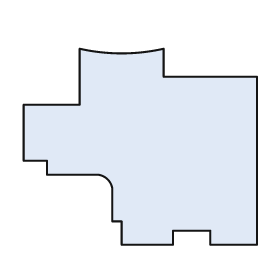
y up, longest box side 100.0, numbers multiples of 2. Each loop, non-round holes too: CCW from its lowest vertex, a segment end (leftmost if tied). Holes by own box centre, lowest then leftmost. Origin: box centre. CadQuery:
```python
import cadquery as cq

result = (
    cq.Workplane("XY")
    .moveTo(-8.0, -42.0)
    .lineTo(14.0, -42.0)
    .lineTo(14.0, -36.0)
    .lineTo(30.0, -36.0)
    .lineTo(30.0, -42.0)
    .lineTo(50.0, -42.0)
    .lineTo(50.0, 30.0)
    .lineTo(10.0, 30.0)
    .lineTo(10.0, 42.0)
    .threePointArc((-8.0, 40.0), (-26.0, 42.0))
    .lineTo(-26.0, 18.0)
    .lineTo(-50.0, 18.0)
    .lineTo(-50.0, -6.0)
    .lineTo(-40.0, -6.0)
    .lineTo(-40.0, -12.0)
    .lineTo(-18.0, -12.0)
    .threePointArc((-14.0, -14.0), (-12.0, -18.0))
    .lineTo(-12.0, -32.0)
    .lineTo(-8.0, -32.0)
    .close()
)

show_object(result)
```